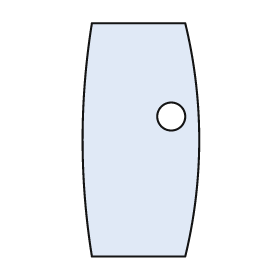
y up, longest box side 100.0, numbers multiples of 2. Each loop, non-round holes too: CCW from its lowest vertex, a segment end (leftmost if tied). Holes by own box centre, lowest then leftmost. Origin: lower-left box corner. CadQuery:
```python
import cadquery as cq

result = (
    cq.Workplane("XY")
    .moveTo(4.0, 0.0)
    .lineTo(44.0, 0.0)
    .threePointArc((50.0, 50.0), (44.0, 100.0))
    .lineTo(4.0, 100.0)
    .threePointArc((0.0, 50.0), (4.0, 0.0))
    .close()
    .moveTo(38.0, 60.0)
    .circle(6.0)
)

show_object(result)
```